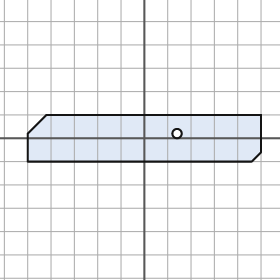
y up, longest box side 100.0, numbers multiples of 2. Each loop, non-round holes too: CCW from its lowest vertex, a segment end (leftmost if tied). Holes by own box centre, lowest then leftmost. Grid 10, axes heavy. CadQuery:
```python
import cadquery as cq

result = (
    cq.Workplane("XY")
    .moveTo(-50.0, -10.0)
    .lineTo(46.0, -10.0)
    .lineTo(50.0, -6.0)
    .lineTo(50.0, 10.0)
    .lineTo(-42.0, 10.0)
    .lineTo(-50.0, 2.0)
    .close()
    .moveTo(14.0, 2.0)
    .circle(2.0)
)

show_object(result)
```